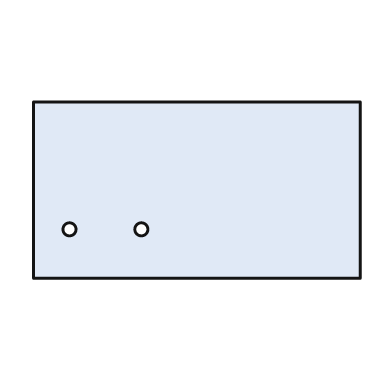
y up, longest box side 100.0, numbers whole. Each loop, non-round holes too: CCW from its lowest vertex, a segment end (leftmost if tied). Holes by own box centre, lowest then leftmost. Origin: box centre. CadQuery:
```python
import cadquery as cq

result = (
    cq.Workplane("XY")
    .moveTo(-50.0, -27.0)
    .lineTo(50.0, -27.0)
    .lineTo(50.0, 27.0)
    .lineTo(-50.0, 27.0)
    .close()
    .moveTo(-39.0, -12.0)
    .circle(2.0)
    .moveTo(-17.0, -12.0)
    .circle(2.0)
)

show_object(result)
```